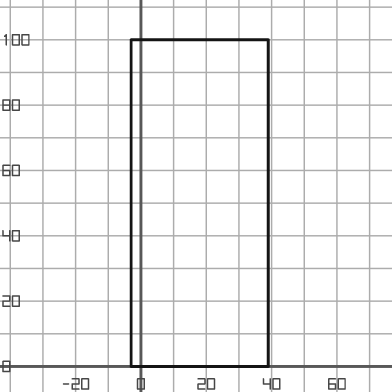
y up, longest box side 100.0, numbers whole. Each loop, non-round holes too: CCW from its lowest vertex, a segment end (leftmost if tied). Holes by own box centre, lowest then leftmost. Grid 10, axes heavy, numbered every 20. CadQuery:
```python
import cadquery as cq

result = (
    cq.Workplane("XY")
    .moveTo(-3.0, 0.0)
    .lineTo(39.0, 0.0)
    .lineTo(39.0, 100.0)
    .lineTo(-3.0, 100.0)
    .close()
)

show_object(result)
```